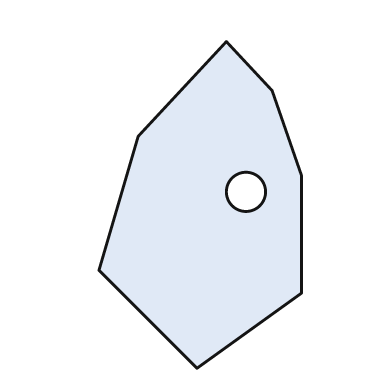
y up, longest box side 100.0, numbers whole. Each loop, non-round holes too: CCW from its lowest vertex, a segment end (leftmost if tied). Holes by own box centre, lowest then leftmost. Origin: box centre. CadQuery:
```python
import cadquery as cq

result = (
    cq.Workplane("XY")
    .moveTo(-1.0, -50.0)
    .lineTo(31.0, -27.0)
    .lineTo(31.0, 9.0)
    .lineTo(22.0, 35.0)
    .lineTo(8.0, 50.0)
    .lineTo(-19.0, 21.0)
    .lineTo(-31.0, -20.0)
    .close()
    .moveTo(14.0, 4.0)
    .circle(6.0)
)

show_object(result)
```